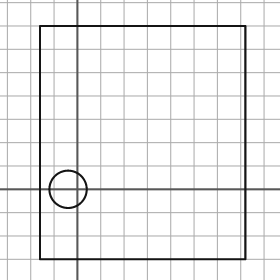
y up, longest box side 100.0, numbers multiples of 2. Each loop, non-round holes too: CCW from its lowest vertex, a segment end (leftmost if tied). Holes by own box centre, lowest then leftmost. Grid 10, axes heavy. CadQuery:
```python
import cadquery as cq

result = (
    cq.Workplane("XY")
    .moveTo(-16.0, -30.0)
    .lineTo(72.0, -30.0)
    .lineTo(72.0, 70.0)
    .lineTo(-16.0, 70.0)
    .close()
    .moveTo(-4.0, 0.0)
    .circle(8.0)
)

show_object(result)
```